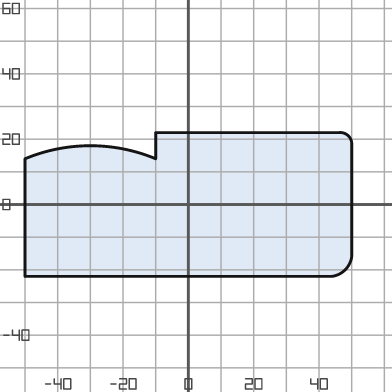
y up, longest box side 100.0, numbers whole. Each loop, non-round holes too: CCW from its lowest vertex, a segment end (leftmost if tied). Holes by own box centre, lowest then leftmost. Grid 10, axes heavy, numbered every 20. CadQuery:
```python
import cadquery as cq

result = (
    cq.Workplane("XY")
    .moveTo(-50.0, -22.0)
    .lineTo(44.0, -22.0)
    .threePointArc((48.0, -20.0), (50.0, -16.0))
    .lineTo(50.0, 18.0)
    .threePointArc((49.0, 21.0), (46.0, 22.0))
    .lineTo(-10.0, 22.0)
    .lineTo(-10.0, 14.0)
    .threePointArc((-30.0, 18.0), (-50.0, 14.0))
    .close()
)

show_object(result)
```